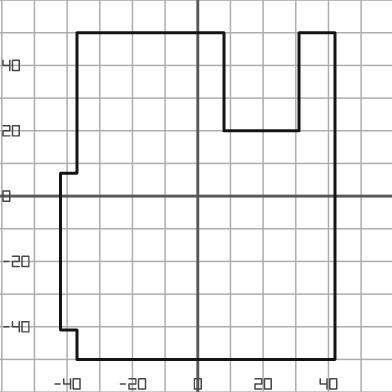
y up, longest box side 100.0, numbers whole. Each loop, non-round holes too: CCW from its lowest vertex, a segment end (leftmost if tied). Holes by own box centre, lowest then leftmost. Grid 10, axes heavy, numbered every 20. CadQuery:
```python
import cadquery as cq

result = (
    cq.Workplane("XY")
    .moveTo(-37.0, -50.0)
    .lineTo(42.0, -50.0)
    .lineTo(42.0, 50.0)
    .lineTo(31.0, 50.0)
    .lineTo(31.0, 20.0)
    .lineTo(8.0, 20.0)
    .lineTo(8.0, 50.0)
    .lineTo(-37.0, 50.0)
    .lineTo(-37.0, 7.0)
    .lineTo(-42.0, 7.0)
    .lineTo(-42.0, -41.0)
    .lineTo(-37.0, -41.0)
    .close()
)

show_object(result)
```